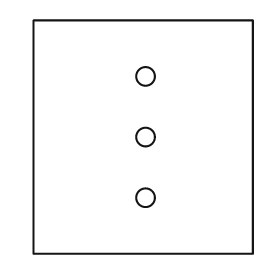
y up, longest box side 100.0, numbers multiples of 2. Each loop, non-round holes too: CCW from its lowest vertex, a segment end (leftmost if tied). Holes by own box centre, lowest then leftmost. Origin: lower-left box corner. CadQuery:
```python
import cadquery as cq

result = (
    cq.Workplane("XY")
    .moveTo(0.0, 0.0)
    .lineTo(94.0, 0.0)
    .lineTo(94.0, 100.0)
    .lineTo(0.0, 100.0)
    .close()
    .moveTo(48.0, 24.0)
    .circle(4.0)
    .moveTo(48.0, 50.0)
    .circle(4.0)
    .moveTo(48.0, 76.0)
    .circle(4.0)
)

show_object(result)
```